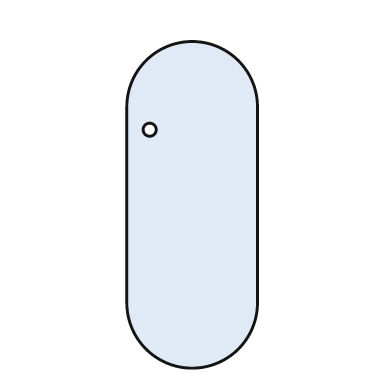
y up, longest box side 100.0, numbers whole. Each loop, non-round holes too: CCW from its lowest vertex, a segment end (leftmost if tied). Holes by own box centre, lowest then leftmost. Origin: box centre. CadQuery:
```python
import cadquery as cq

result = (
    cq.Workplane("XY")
    .moveTo(-20.0, -30.0)
    .threePointArc((0.0, -50.0), (20.0, -30.0))
    .lineTo(20.0, 30.0)
    .threePointArc((0.0, 50.0), (-20.0, 30.0))
    .close()
    .moveTo(-13.0, 23.0)
    .circle(2.0)
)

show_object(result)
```